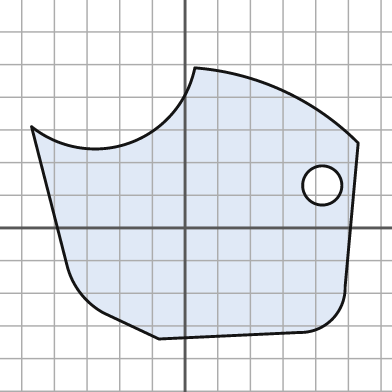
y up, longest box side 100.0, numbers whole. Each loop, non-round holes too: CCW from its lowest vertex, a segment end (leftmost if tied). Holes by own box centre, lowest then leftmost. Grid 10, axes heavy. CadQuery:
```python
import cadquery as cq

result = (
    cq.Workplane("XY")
    .moveTo(-8.0, -34.0)
    .lineTo(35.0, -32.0)
    .threePointArc((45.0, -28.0), (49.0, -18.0))
    .lineTo(53.0, 26.0)
    .threePointArc((30.0, 42.0), (3.0, 49.0))
    .threePointArc((-17.0, 26.0), (-47.0, 31.0))
    .lineTo(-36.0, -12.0)
    .threePointArc((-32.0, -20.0), (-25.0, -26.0))
    .close()
    .moveTo(42.0, 13.0)
    .circle(6.0)
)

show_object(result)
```